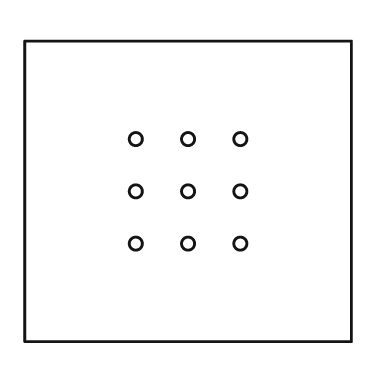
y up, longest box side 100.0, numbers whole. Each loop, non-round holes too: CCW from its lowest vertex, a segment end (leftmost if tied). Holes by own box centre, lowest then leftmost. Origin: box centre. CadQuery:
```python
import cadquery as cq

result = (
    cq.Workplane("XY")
    .moveTo(-50.0, -46.0)
    .lineTo(50.0, -46.0)
    .lineTo(50.0, 46.0)
    .lineTo(-50.0, 46.0)
    .close()
    .moveTo(-16.0, -16.0)
    .circle(2.0)
    .moveTo(0.0, -16.0)
    .circle(2.0)
    .moveTo(16.0, -16.0)
    .circle(2.0)
    .moveTo(-16.0, 0.0)
    .circle(2.0)
    .moveTo(0.0, 0.0)
    .circle(2.0)
    .moveTo(16.0, 0.0)
    .circle(2.0)
    .moveTo(-16.0, 16.0)
    .circle(2.0)
    .moveTo(0.0, 16.0)
    .circle(2.0)
    .moveTo(16.0, 16.0)
    .circle(2.0)
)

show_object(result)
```